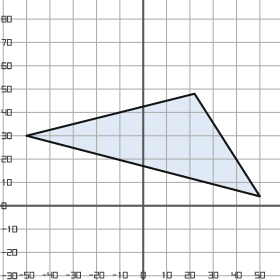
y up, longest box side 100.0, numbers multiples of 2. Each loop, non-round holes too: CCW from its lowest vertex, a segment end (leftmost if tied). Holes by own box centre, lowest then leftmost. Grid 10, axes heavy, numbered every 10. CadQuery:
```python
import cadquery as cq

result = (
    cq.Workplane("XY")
    .moveTo(50.0, 4.0)
    .lineTo(22.0, 48.0)
    .lineTo(-50.0, 30.0)
    .close()
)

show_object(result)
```